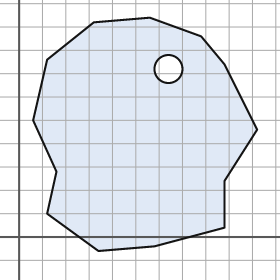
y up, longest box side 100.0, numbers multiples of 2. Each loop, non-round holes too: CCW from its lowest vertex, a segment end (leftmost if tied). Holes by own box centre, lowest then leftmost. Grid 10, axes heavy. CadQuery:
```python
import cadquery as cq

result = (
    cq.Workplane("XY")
    .moveTo(34.0, -6.0)
    .lineTo(58.0, -4.0)
    .lineTo(88.0, 4.0)
    .lineTo(88.0, 24.0)
    .lineTo(102.0, 46.0)
    .lineTo(88.0, 74.0)
    .lineTo(78.0, 86.0)
    .lineTo(56.0, 94.0)
    .lineTo(32.0, 92.0)
    .lineTo(12.0, 76.0)
    .lineTo(6.0, 50.0)
    .lineTo(16.0, 28.0)
    .lineTo(12.0, 10.0)
    .close()
    .moveTo(64.0, 72.0)
    .circle(6.0)
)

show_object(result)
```